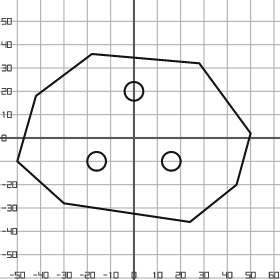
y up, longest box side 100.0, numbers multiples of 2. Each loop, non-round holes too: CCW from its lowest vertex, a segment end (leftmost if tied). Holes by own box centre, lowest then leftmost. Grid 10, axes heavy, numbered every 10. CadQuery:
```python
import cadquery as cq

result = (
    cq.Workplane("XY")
    .moveTo(24.0, -36.0)
    .lineTo(44.0, -20.0)
    .lineTo(50.0, 2.0)
    .lineTo(28.0, 32.0)
    .lineTo(-18.0, 36.0)
    .lineTo(-42.0, 18.0)
    .lineTo(-50.0, -10.0)
    .lineTo(-30.0, -28.0)
    .close()
    .moveTo(-16.0, -10.0)
    .circle(4.0)
    .moveTo(16.0, -10.0)
    .circle(4.0)
    .moveTo(0.0, 20.0)
    .circle(4.0)
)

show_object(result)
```